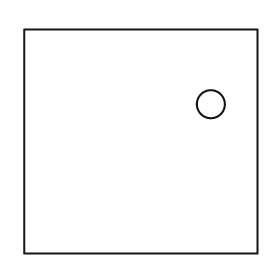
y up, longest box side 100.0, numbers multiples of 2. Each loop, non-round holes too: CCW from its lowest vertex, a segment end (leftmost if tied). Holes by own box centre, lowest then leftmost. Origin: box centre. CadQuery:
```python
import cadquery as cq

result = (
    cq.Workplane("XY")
    .moveTo(-50.0, -48.0)
    .lineTo(50.0, -48.0)
    .lineTo(50.0, 48.0)
    .lineTo(-50.0, 48.0)
    .close()
    .moveTo(30.0, 16.0)
    .circle(6.0)
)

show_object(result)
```